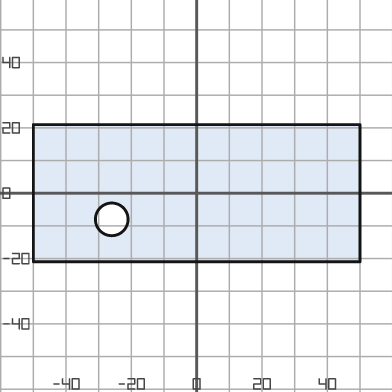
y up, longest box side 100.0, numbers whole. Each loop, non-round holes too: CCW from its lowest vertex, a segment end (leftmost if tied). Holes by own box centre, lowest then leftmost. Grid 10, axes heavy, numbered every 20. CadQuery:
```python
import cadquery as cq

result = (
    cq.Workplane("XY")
    .moveTo(-50.0, -21.0)
    .lineTo(50.0, -21.0)
    .lineTo(50.0, 21.0)
    .lineTo(-50.0, 21.0)
    .close()
    .moveTo(-26.0, -8.0)
    .circle(5.0)
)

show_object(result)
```